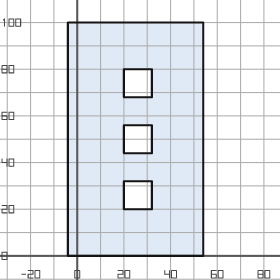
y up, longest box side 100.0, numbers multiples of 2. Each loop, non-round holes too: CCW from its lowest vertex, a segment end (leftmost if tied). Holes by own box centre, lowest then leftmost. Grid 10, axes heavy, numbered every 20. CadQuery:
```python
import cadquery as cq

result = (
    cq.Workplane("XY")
    .moveTo(-4.0, 0.0)
    .lineTo(54.0, 0.0)
    .lineTo(54.0, 100.0)
    .lineTo(-4.0, 100.0)
    .close()
    .moveTo(20.0, 20.0)
    .lineTo(32.0, 20.0)
    .lineTo(32.0, 32.0)
    .lineTo(20.0, 32.0)
    .close()
    .moveTo(20.0, 44.0)
    .lineTo(32.0, 44.0)
    .lineTo(32.0, 56.0)
    .lineTo(20.0, 56.0)
    .close()
    .moveTo(20.0, 68.0)
    .lineTo(32.0, 68.0)
    .lineTo(32.0, 80.0)
    .lineTo(20.0, 80.0)
    .close()
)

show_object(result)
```